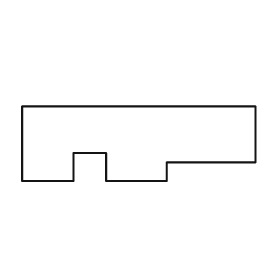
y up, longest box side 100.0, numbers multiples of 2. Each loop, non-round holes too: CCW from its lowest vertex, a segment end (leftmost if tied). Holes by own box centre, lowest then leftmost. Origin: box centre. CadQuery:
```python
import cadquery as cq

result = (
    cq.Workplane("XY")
    .moveTo(-50.0, -16.0)
    .lineTo(-28.0, -16.0)
    .lineTo(-28.0, -4.0)
    .lineTo(-14.0, -4.0)
    .lineTo(-14.0, -16.0)
    .lineTo(12.0, -16.0)
    .lineTo(12.0, -8.0)
    .lineTo(50.0, -8.0)
    .lineTo(50.0, 16.0)
    .lineTo(-50.0, 16.0)
    .close()
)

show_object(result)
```